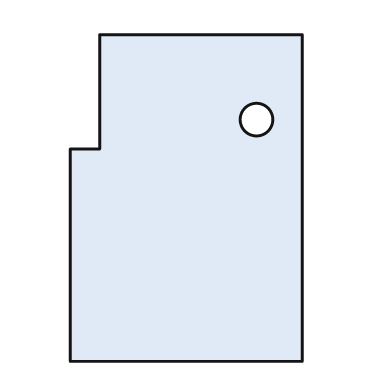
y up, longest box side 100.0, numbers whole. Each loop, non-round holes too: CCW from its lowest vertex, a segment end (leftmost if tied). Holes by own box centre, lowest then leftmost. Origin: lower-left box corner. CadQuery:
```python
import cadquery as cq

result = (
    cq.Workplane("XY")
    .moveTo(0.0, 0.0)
    .lineTo(71.0, 0.0)
    .lineTo(71.0, 100.0)
    .lineTo(9.0, 100.0)
    .lineTo(9.0, 65.0)
    .lineTo(0.0, 65.0)
    .close()
    .moveTo(57.0, 74.0)
    .circle(5.0)
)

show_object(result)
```